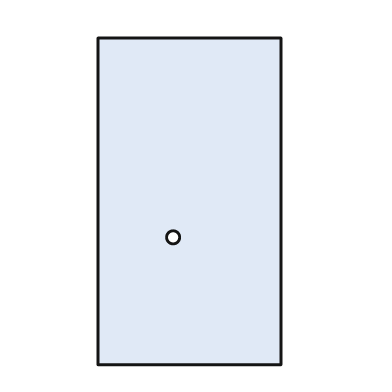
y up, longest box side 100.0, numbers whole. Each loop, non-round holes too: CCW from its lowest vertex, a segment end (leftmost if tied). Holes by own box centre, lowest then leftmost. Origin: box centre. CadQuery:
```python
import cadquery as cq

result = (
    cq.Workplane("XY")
    .moveTo(-28.0, -50.0)
    .lineTo(28.0, -50.0)
    .lineTo(28.0, 50.0)
    .lineTo(-28.0, 50.0)
    .close()
    .moveTo(-5.0, -11.0)
    .circle(2.0)
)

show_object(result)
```